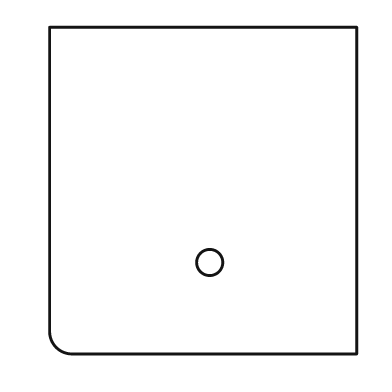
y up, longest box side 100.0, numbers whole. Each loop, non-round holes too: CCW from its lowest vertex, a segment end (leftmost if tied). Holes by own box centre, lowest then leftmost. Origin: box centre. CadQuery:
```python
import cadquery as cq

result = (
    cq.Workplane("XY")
    .moveTo(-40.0, -50.0)
    .lineTo(47.0, -50.0)
    .lineTo(47.0, 50.0)
    .lineTo(-47.0, 50.0)
    .lineTo(-47.0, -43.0)
    .threePointArc((-45.0, -48.0), (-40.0, -50.0))
    .close()
    .moveTo(2.0, -22.0)
    .circle(4.0)
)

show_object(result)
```